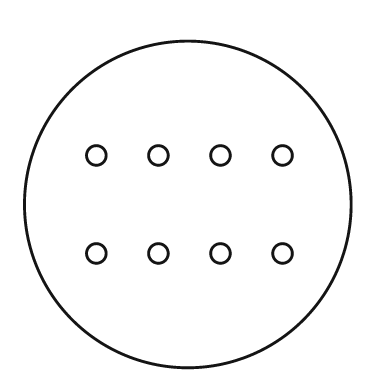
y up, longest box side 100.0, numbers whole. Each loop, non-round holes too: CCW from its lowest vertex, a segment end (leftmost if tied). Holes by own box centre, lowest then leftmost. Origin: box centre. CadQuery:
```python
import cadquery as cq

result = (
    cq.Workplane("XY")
    .moveTo(0.0, 0.0)
    .circle(50.0)
    .moveTo(-28.0, -15.0)
    .circle(3.0)
    .moveTo(-9.0, -15.0)
    .circle(3.0)
    .moveTo(10.0, -15.0)
    .circle(3.0)
    .moveTo(29.0, -15.0)
    .circle(3.0)
    .moveTo(-28.0, 15.0)
    .circle(3.0)
    .moveTo(-9.0, 15.0)
    .circle(3.0)
    .moveTo(10.0, 15.0)
    .circle(3.0)
    .moveTo(29.0, 15.0)
    .circle(3.0)
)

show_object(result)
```